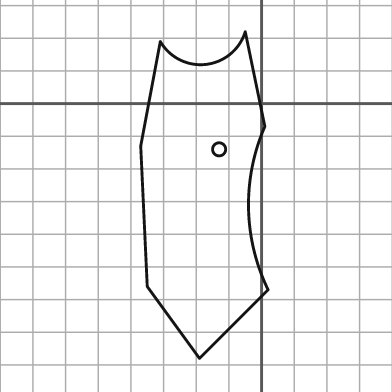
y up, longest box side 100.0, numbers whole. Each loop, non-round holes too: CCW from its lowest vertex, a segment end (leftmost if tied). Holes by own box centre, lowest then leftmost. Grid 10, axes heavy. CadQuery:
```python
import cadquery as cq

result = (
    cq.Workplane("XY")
    .moveTo(-19.0, -78.0)
    .lineTo(2.0, -57.0)
    .threePointArc((-4.0, -32.0), (1.0, -7.0))
    .lineTo(-5.0, 22.0)
    .threePointArc((-17.0, 12.0), (-31.0, 19.0))
    .lineTo(-37.0, -13.0)
    .lineTo(-35.0, -56.0)
    .close()
    .moveTo(-13.0, -14.0)
    .circle(2.0)
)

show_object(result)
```